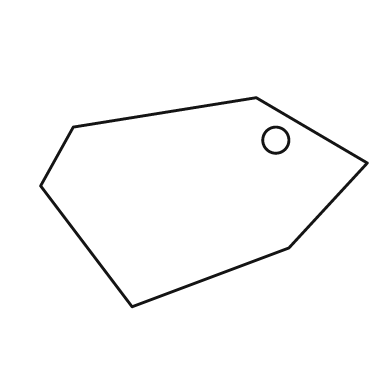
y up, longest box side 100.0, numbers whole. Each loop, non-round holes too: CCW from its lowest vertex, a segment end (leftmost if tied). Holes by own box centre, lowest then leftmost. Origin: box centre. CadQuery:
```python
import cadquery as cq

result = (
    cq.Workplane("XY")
    .moveTo(-22.0, -32.0)
    .lineTo(26.0, -14.0)
    .lineTo(50.0, 12.0)
    .lineTo(16.0, 32.0)
    .lineTo(-40.0, 23.0)
    .lineTo(-50.0, 5.0)
    .close()
    .moveTo(22.0, 19.0)
    .circle(4.0)
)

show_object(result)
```